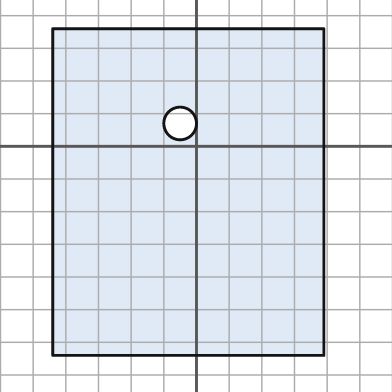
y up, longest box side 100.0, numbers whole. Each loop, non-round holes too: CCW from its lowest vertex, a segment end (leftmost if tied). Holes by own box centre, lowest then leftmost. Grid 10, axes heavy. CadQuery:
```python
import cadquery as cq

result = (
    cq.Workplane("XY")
    .moveTo(-44.0, -64.0)
    .lineTo(39.0, -64.0)
    .lineTo(39.0, 36.0)
    .lineTo(-44.0, 36.0)
    .close()
    .moveTo(-5.0, 7.0)
    .circle(5.0)
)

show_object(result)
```